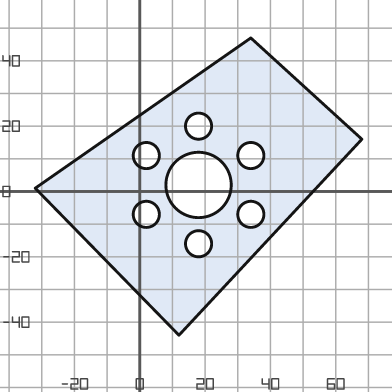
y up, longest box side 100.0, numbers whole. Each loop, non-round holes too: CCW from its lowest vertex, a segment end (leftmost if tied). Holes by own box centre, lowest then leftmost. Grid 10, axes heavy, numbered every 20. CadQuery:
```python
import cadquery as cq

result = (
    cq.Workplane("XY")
    .moveTo(12.0, -44.0)
    .lineTo(68.0, 16.0)
    .lineTo(34.0, 47.0)
    .lineTo(-32.0, 1.0)
    .close()
    .moveTo(18.0, -16.0)
    .circle(4.0)
    .moveTo(2.0, -7.0)
    .circle(4.0)
    .moveTo(34.0, -7.0)
    .circle(4.0)
    .moveTo(18.0, 2.0)
    .circle(10.0)
    .moveTo(2.0, 11.0)
    .circle(4.0)
    .moveTo(34.0, 11.0)
    .circle(4.0)
    .moveTo(18.0, 20.0)
    .circle(4.0)
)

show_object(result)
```